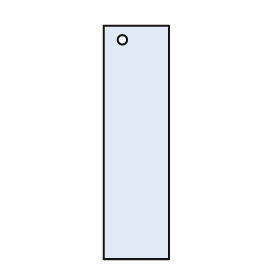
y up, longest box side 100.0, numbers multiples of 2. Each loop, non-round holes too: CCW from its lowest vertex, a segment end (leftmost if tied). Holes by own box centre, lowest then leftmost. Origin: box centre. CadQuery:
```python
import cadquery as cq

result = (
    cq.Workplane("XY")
    .moveTo(-14.0, -50.0)
    .lineTo(14.0, -50.0)
    .lineTo(14.0, 50.0)
    .lineTo(-14.0, 50.0)
    .close()
    .moveTo(-6.0, 44.0)
    .circle(2.0)
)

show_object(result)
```